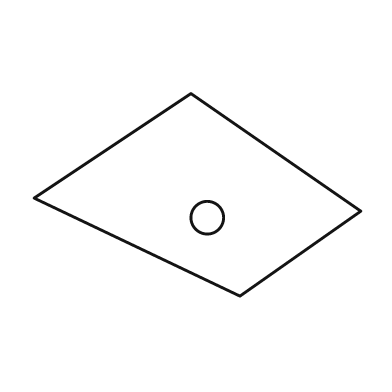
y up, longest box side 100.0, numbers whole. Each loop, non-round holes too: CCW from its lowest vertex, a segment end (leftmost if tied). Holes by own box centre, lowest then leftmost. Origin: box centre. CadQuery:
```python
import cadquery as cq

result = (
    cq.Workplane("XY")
    .moveTo(13.0, -31.0)
    .lineTo(50.0, -5.0)
    .lineTo(-2.0, 31.0)
    .lineTo(-50.0, -1.0)
    .close()
    .moveTo(3.0, -7.0)
    .circle(5.0)
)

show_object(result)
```